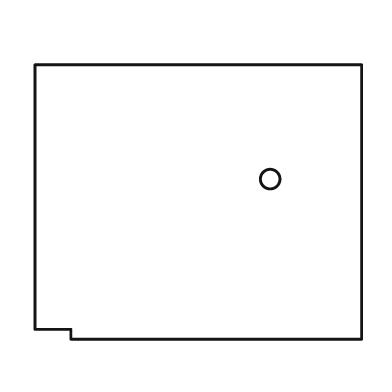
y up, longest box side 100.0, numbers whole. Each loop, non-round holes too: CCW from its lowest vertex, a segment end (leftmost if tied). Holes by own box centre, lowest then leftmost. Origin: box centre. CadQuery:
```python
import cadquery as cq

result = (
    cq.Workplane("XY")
    .moveTo(-39.0, -42.0)
    .lineTo(50.0, -42.0)
    .lineTo(50.0, 42.0)
    .lineTo(-50.0, 42.0)
    .lineTo(-50.0, -39.0)
    .lineTo(-39.0, -39.0)
    .close()
    .moveTo(22.0, 7.0)
    .circle(3.0)
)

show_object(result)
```